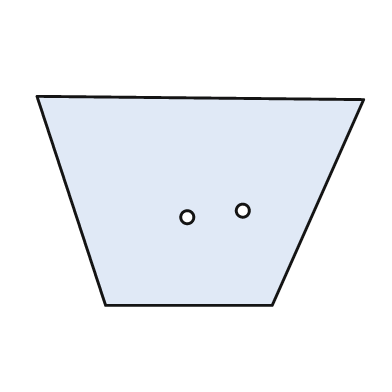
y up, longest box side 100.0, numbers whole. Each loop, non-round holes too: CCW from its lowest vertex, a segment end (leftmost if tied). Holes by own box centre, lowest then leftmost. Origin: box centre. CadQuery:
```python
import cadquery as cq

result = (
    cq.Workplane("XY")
    .moveTo(-29.0, -32.0)
    .lineTo(22.0, -32.0)
    .lineTo(50.0, 31.0)
    .lineTo(-50.0, 32.0)
    .close()
    .moveTo(-4.0, -5.0)
    .circle(2.0)
    .moveTo(13.0, -3.0)
    .circle(2.0)
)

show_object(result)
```